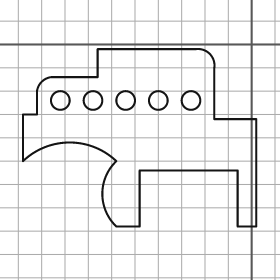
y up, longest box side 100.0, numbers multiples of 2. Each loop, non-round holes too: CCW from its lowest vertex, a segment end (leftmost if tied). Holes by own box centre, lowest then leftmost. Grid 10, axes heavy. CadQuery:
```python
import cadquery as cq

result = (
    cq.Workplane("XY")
    .moveTo(-58.0, -78.0)
    .lineTo(-48.0, -78.0)
    .lineTo(-48.0, -54.0)
    .lineTo(-6.0, -54.0)
    .lineTo(-6.0, -78.0)
    .lineTo(2.0, -78.0)
    .lineTo(2.0, -32.0)
    .lineTo(-16.0, -32.0)
    .lineTo(-16.0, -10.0)
    .threePointArc((-18.0, -4.0), (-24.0, -2.0))
    .lineTo(-66.0, -2.0)
    .lineTo(-66.0, -14.0)
    .lineTo(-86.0, -14.0)
    .threePointArc((-90.0, -16.0), (-92.0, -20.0))
    .lineTo(-92.0, -30.0)
    .lineTo(-98.0, -30.0)
    .lineTo(-98.0, -50.0)
    .threePointArc((-78.0, -42.0), (-58.0, -50.0))
    .threePointArc((-64.0, -64.0), (-58.0, -78.0))
    .close()
    .moveTo(-82.0, -24.0)
    .circle(4.0)
    .moveTo(-68.0, -24.0)
    .circle(4.0)
    .moveTo(-54.0, -24.0)
    .circle(4.0)
    .moveTo(-40.0, -24.0)
    .circle(4.0)
    .moveTo(-26.0, -24.0)
    .circle(4.0)
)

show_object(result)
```